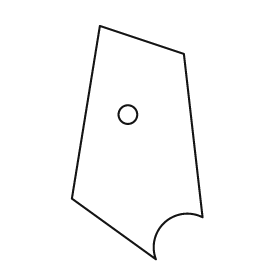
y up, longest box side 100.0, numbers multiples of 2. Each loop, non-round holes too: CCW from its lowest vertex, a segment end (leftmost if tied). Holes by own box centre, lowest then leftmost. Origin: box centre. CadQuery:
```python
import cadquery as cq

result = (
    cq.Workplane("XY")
    .moveTo(8.0, -50.0)
    .threePointArc((12.0, -34.0), (28.0, -32.0))
    .lineTo(20.0, 38.0)
    .lineTo(-16.0, 50.0)
    .lineTo(-28.0, -24.0)
    .close()
    .moveTo(-4.0, 12.0)
    .circle(4.0)
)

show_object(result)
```